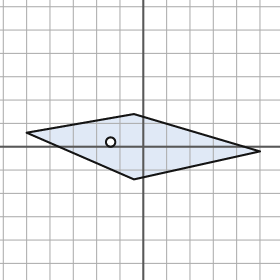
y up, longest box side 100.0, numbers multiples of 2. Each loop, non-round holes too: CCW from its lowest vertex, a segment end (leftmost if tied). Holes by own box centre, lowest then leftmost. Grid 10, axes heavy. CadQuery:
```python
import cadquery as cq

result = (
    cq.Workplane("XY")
    .moveTo(-4.0, -14.0)
    .lineTo(50.0, -2.0)
    .lineTo(-4.0, 14.0)
    .lineTo(-50.0, 6.0)
    .close()
    .moveTo(-14.0, 2.0)
    .circle(2.0)
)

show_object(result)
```